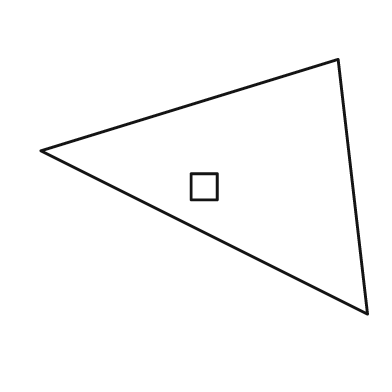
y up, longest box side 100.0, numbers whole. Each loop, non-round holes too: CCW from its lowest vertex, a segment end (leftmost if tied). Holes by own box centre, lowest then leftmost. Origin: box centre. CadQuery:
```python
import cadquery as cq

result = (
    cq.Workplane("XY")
    .moveTo(50.0, -39.0)
    .lineTo(41.0, 39.0)
    .lineTo(-50.0, 11.0)
    .close()
    .moveTo(-4.0, -4.0)
    .lineTo(4.0, -4.0)
    .lineTo(4.0, 4.0)
    .lineTo(-4.0, 4.0)
    .close()
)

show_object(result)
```